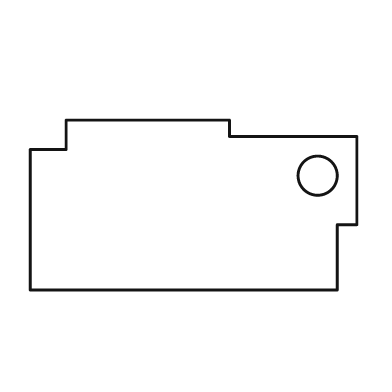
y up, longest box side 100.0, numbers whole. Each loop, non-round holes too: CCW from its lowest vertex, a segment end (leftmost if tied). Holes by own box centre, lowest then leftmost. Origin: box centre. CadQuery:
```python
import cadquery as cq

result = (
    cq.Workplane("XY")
    .moveTo(-50.0, -26.0)
    .lineTo(44.0, -26.0)
    .lineTo(44.0, -6.0)
    .lineTo(50.0, -6.0)
    .lineTo(50.0, 21.0)
    .lineTo(11.0, 21.0)
    .lineTo(11.0, 26.0)
    .lineTo(-39.0, 26.0)
    .lineTo(-39.0, 17.0)
    .lineTo(-50.0, 17.0)
    .close()
    .moveTo(38.0, 9.0)
    .circle(6.0)
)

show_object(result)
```